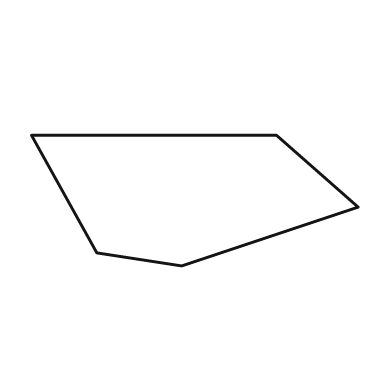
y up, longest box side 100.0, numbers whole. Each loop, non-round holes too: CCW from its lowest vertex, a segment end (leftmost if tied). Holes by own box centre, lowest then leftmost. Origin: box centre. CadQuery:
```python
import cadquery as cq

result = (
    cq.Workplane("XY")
    .moveTo(-4.0, -20.0)
    .lineTo(50.0, -2.0)
    .lineTo(25.0, 20.0)
    .lineTo(-50.0, 20.0)
    .lineTo(-30.0, -16.0)
    .close()
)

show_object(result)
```